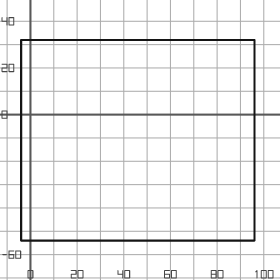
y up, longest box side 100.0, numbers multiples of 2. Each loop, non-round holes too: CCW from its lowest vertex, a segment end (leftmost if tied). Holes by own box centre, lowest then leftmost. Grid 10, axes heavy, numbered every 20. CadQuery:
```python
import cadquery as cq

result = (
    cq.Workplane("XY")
    .moveTo(-4.0, -54.0)
    .lineTo(96.0, -54.0)
    .lineTo(96.0, 32.0)
    .lineTo(-4.0, 32.0)
    .close()
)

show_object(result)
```